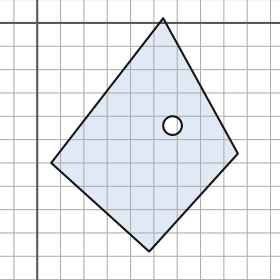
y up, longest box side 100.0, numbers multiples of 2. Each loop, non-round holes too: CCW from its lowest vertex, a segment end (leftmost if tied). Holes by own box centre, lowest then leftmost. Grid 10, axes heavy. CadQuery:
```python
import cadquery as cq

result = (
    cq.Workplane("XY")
    .moveTo(48.0, -98.0)
    .lineTo(86.0, -56.0)
    .lineTo(54.0, 2.0)
    .lineTo(6.0, -60.0)
    .close()
    .moveTo(58.0, -44.0)
    .circle(4.0)
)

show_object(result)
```